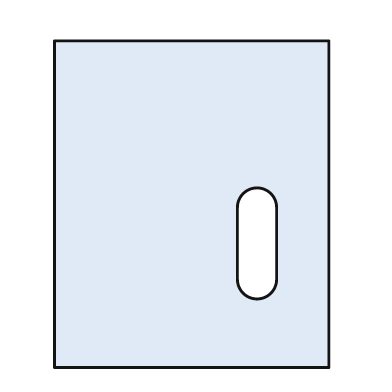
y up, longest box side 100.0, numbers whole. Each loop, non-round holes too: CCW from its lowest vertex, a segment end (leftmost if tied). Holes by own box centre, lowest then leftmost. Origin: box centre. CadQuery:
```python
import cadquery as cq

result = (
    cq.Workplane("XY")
    .moveTo(-42.0, -50.0)
    .lineTo(42.0, -50.0)
    .lineTo(42.0, 50.0)
    .lineTo(-42.0, 50.0)
    .close()
    .moveTo(14.0, -23.0)
    .threePointArc((20.0, -29.0), (26.0, -23.0))
    .lineTo(26.0, -1.0)
    .threePointArc((20.0, 5.0), (14.0, -1.0))
    .close()
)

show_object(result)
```